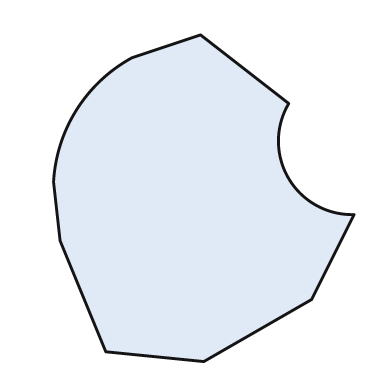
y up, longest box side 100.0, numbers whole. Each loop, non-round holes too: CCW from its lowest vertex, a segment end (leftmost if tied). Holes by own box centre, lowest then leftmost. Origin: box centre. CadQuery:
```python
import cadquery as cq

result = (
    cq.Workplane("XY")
    .moveTo(0.0, -50.0)
    .lineTo(33.0, -31.0)
    .lineTo(46.0, -5.0)
    .threePointArc((26.0, 6.0), (26.0, 29.0))
    .lineTo(-1.0, 50.0)
    .lineTo(-22.0, 43.0)
    .threePointArc((-39.0, 27.0), (-46.0, 5.0))
    .lineTo(-44.0, -13.0)
    .lineTo(-30.0, -47.0)
    .close()
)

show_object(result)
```